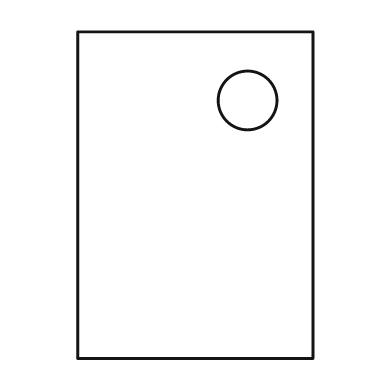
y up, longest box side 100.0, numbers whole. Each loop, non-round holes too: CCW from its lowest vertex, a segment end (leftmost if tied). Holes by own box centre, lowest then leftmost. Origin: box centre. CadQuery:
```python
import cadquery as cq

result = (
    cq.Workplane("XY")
    .moveTo(-36.0, -50.0)
    .lineTo(36.0, -50.0)
    .lineTo(36.0, 50.0)
    .lineTo(-36.0, 50.0)
    .close()
    .moveTo(16.0, 29.0)
    .circle(9.0)
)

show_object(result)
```